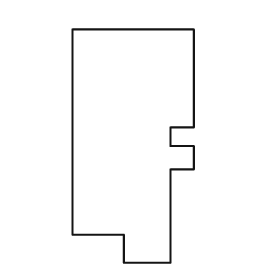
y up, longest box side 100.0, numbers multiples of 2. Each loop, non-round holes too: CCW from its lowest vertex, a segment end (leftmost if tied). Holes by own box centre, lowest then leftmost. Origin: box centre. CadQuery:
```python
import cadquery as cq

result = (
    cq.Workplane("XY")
    .moveTo(-4.0, -50.0)
    .lineTo(16.0, -50.0)
    .lineTo(16.0, -10.0)
    .lineTo(26.0, -10.0)
    .lineTo(26.0, 0.0)
    .lineTo(16.0, 0.0)
    .lineTo(16.0, 8.0)
    .lineTo(26.0, 8.0)
    .lineTo(26.0, 50.0)
    .lineTo(-26.0, 50.0)
    .lineTo(-26.0, -38.0)
    .lineTo(-4.0, -38.0)
    .close()
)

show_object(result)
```